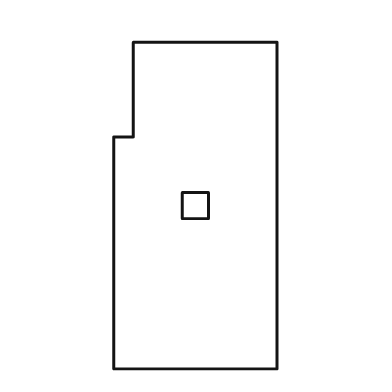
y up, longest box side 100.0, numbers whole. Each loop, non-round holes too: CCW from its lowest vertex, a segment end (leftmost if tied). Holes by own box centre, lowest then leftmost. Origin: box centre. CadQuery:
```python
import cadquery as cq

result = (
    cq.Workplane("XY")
    .moveTo(-25.0, -50.0)
    .lineTo(25.0, -50.0)
    .lineTo(25.0, 50.0)
    .lineTo(-19.0, 50.0)
    .lineTo(-19.0, 21.0)
    .lineTo(-25.0, 21.0)
    .close()
    .moveTo(-4.0, -4.0)
    .lineTo(4.0, -4.0)
    .lineTo(4.0, 4.0)
    .lineTo(-4.0, 4.0)
    .close()
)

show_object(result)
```